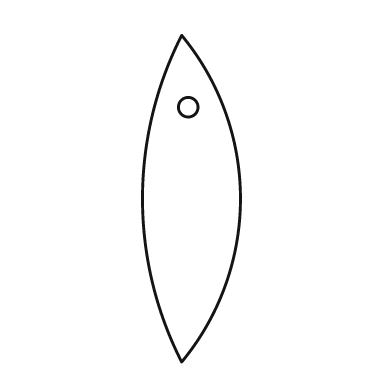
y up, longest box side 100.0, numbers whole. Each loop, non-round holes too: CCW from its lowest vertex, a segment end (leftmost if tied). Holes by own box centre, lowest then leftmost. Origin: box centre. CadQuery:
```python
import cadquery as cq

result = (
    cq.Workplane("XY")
    .moveTo(-3.0, -50.0)
    .threePointArc((15.0, 0.0), (-3.0, 50.0))
    .threePointArc((-15.0, 0.0), (-3.0, -50.0))
    .close()
    .moveTo(-1.0, 28.0)
    .circle(3.0)
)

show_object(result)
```